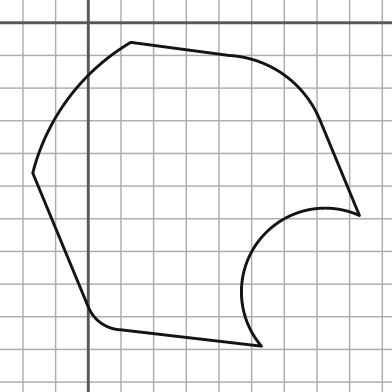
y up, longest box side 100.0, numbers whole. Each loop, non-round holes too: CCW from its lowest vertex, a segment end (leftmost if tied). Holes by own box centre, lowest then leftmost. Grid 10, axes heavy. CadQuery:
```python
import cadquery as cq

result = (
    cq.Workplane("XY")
    .moveTo(53.0, -99.0)
    .threePointArc((52.0, -67.0), (83.0, -59.0))
    .lineTo(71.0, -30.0)
    .threePointArc((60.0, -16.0), (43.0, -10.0))
    .lineTo(13.0, -6.0)
    .threePointArc((-6.0, -23.0), (-17.0, -46.0))
    .lineTo(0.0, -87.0)
    .threePointArc((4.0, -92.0), (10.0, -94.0))
    .close()
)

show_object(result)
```